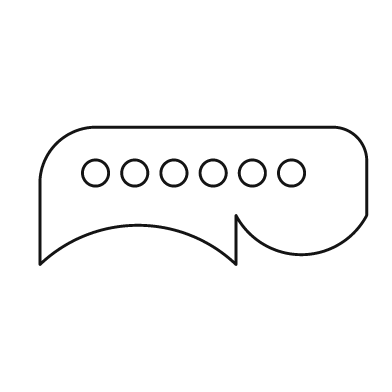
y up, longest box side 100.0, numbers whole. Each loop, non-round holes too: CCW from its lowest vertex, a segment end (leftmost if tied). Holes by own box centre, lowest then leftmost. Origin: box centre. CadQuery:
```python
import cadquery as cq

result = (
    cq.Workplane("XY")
    .moveTo(-50.0, -21.0)
    .threePointArc((-20.0, -9.0), (10.0, -21.0))
    .lineTo(10.0, -6.0)
    .threePointArc((30.0, -18.0), (50.0, -6.0))
    .lineTo(50.0, 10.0)
    .threePointArc((47.0, 18.0), (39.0, 21.0))
    .lineTo(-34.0, 21.0)
    .threePointArc((-45.0, 16.0), (-50.0, 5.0))
    .close()
    .moveTo(-33.0, 7.0)
    .circle(4.0)
    .moveTo(-21.0, 7.0)
    .circle(4.0)
    .moveTo(-9.0, 7.0)
    .circle(4.0)
    .moveTo(3.0, 7.0)
    .circle(4.0)
    .moveTo(15.0, 7.0)
    .circle(4.0)
    .moveTo(27.0, 7.0)
    .circle(4.0)
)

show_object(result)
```